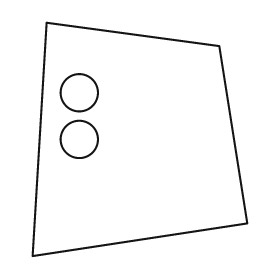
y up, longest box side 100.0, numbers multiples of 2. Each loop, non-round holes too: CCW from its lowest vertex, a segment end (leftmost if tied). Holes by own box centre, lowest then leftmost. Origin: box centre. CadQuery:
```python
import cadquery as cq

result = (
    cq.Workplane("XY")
    .moveTo(-46.0, -50.0)
    .lineTo(46.0, -36.0)
    .lineTo(34.0, 40.0)
    .lineTo(-40.0, 50.0)
    .close()
    .moveTo(-26.0, 0.0)
    .circle(8.0)
    .moveTo(-26.0, 20.0)
    .circle(8.0)
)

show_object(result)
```